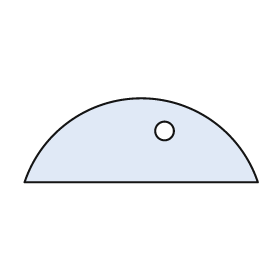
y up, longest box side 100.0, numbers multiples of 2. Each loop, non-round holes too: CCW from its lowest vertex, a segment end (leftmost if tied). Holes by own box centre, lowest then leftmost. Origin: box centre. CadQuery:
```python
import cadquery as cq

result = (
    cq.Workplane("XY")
    .moveTo(-50.0, -18.0)
    .lineTo(50.0, -18.0)
    .threePointArc((0.0, 18.0), (-50.0, -18.0))
    .close()
    .moveTo(10.0, 4.0)
    .circle(4.0)
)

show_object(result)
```